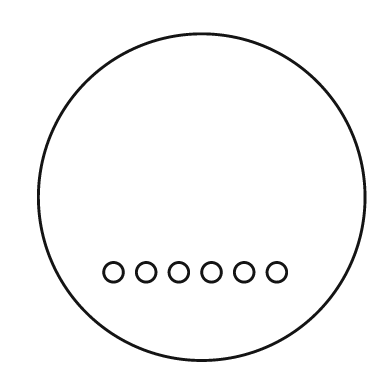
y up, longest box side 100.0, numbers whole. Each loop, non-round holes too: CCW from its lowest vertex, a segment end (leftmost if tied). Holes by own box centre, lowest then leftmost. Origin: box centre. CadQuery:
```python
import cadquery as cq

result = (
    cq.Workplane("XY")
    .moveTo(0.0, 0.0)
    .circle(50.0)
    .moveTo(-27.0, -23.0)
    .circle(3.0)
    .moveTo(-17.0, -23.0)
    .circle(3.0)
    .moveTo(-7.0, -23.0)
    .circle(3.0)
    .moveTo(3.0, -23.0)
    .circle(3.0)
    .moveTo(13.0, -23.0)
    .circle(3.0)
    .moveTo(23.0, -23.0)
    .circle(3.0)
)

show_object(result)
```